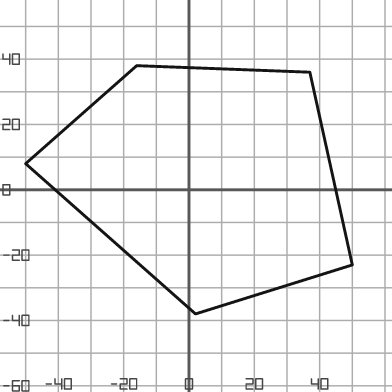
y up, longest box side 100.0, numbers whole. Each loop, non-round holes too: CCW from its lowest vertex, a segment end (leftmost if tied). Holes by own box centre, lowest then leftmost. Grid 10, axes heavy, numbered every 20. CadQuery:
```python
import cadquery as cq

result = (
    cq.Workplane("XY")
    .moveTo(2.0, -38.0)
    .lineTo(50.0, -23.0)
    .lineTo(37.0, 36.0)
    .lineTo(-16.0, 38.0)
    .lineTo(-50.0, 8.0)
    .close()
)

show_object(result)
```